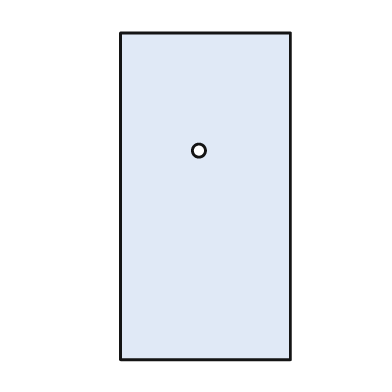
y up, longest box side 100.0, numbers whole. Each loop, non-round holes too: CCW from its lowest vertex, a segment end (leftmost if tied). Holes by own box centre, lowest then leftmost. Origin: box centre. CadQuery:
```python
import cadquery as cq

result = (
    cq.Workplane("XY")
    .moveTo(-26.0, -50.0)
    .lineTo(26.0, -50.0)
    .lineTo(26.0, 50.0)
    .lineTo(-26.0, 50.0)
    .close()
    .moveTo(-2.0, 14.0)
    .circle(2.0)
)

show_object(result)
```